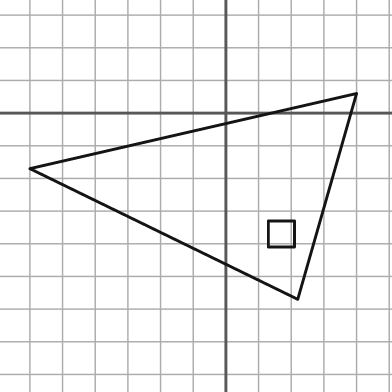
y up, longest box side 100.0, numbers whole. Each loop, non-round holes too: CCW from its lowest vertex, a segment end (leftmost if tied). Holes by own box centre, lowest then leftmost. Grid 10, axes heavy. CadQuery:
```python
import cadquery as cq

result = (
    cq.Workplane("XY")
    .moveTo(22.0, -57.0)
    .lineTo(40.0, 6.0)
    .lineTo(-60.0, -17.0)
    .close()
    .moveTo(13.0, -41.0)
    .lineTo(21.0, -41.0)
    .lineTo(21.0, -33.0)
    .lineTo(13.0, -33.0)
    .close()
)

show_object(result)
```